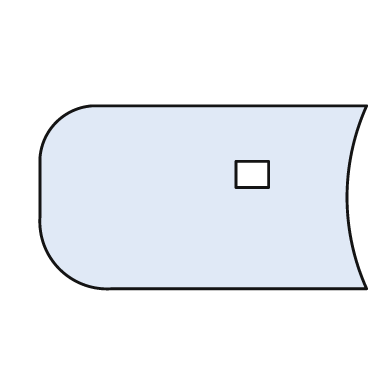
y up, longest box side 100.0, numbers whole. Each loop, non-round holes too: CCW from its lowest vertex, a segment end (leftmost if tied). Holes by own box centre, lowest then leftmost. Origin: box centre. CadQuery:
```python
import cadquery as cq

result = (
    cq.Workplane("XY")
    .moveTo(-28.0, -28.0)
    .lineTo(50.0, -28.0)
    .threePointArc((44.0, 0.0), (50.0, 28.0))
    .lineTo(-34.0, 28.0)
    .threePointArc((-45.0, 23.0), (-50.0, 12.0))
    .lineTo(-50.0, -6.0)
    .threePointArc((-44.0, -22.0), (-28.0, -28.0))
    .close()
    .moveTo(10.0, 3.0)
    .lineTo(20.0, 3.0)
    .lineTo(20.0, 11.0)
    .lineTo(10.0, 11.0)
    .close()
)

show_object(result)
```